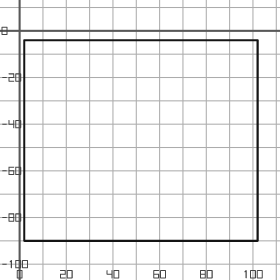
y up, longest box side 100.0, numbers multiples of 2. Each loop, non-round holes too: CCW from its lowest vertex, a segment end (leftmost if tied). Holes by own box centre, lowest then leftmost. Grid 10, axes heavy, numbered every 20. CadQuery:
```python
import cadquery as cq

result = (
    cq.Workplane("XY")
    .moveTo(2.0, -90.0)
    .lineTo(102.0, -90.0)
    .lineTo(102.0, -4.0)
    .lineTo(2.0, -4.0)
    .close()
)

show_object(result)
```